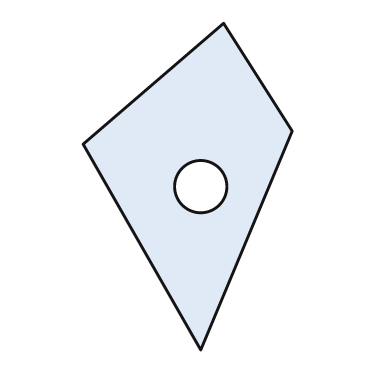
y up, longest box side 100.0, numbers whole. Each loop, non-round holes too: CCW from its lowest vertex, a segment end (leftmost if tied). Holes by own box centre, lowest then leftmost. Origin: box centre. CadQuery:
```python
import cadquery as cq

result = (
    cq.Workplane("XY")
    .moveTo(4.0, -50.0)
    .lineTo(32.0, 17.0)
    .lineTo(11.0, 50.0)
    .lineTo(-32.0, 13.0)
    .close()
    .moveTo(4.0, 0.0)
    .circle(8.0)
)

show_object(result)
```